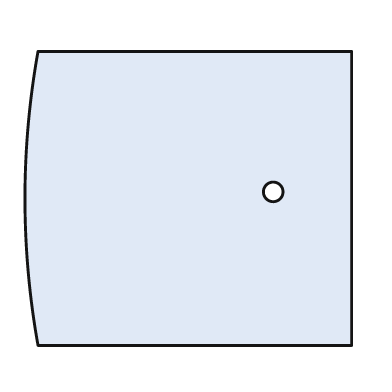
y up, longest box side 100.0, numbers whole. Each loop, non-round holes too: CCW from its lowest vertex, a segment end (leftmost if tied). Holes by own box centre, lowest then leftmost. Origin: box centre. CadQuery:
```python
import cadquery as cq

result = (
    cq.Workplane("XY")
    .moveTo(-46.0, -45.0)
    .lineTo(50.0, -45.0)
    .lineTo(50.0, 45.0)
    .lineTo(-46.0, 45.0)
    .threePointArc((-50.0, 0.0), (-46.0, -45.0))
    .close()
    .moveTo(26.0, 2.0)
    .circle(3.0)
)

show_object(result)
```